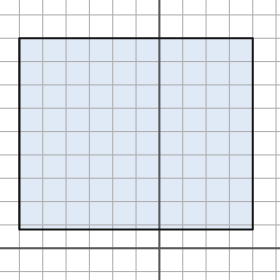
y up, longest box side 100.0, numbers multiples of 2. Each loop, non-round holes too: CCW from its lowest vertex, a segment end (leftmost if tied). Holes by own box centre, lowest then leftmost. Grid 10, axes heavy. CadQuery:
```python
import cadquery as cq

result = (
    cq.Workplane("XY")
    .moveTo(-60.0, 8.0)
    .lineTo(40.0, 8.0)
    .lineTo(40.0, 90.0)
    .lineTo(-60.0, 90.0)
    .close()
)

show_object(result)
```